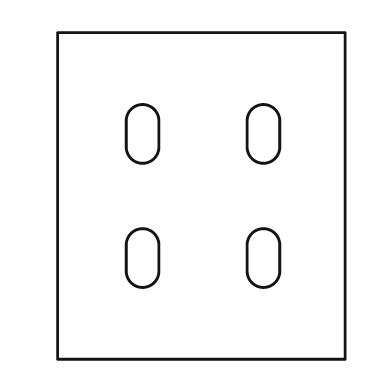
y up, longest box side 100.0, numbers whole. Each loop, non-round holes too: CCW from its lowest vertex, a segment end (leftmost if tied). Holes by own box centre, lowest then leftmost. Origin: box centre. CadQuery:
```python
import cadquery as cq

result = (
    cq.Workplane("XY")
    .moveTo(-44.0, -50.0)
    .lineTo(44.0, -50.0)
    .lineTo(44.0, 50.0)
    .lineTo(-44.0, 50.0)
    .close()
    .moveTo(-23.0, -23.0)
    .threePointArc((-18.0, -28.0), (-13.0, -23.0))
    .lineTo(-13.0, -15.0)
    .threePointArc((-18.0, -10.0), (-23.0, -15.0))
    .close()
    .moveTo(14.0, -23.0)
    .threePointArc((19.0, -28.0), (24.0, -23.0))
    .lineTo(24.0, -15.0)
    .threePointArc((19.0, -10.0), (14.0, -15.0))
    .close()
    .moveTo(-23.0, 15.0)
    .threePointArc((-18.0, 10.0), (-13.0, 15.0))
    .lineTo(-13.0, 23.0)
    .threePointArc((-18.0, 28.0), (-23.0, 23.0))
    .close()
    .moveTo(14.0, 15.0)
    .threePointArc((19.0, 10.0), (24.0, 15.0))
    .lineTo(24.0, 23.0)
    .threePointArc((19.0, 28.0), (14.0, 23.0))
    .close()
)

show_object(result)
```